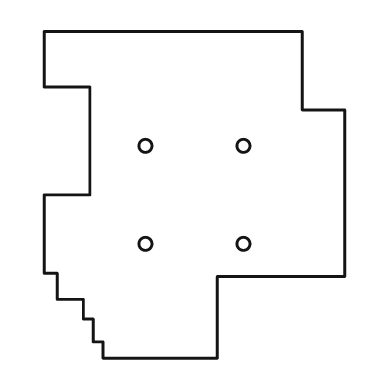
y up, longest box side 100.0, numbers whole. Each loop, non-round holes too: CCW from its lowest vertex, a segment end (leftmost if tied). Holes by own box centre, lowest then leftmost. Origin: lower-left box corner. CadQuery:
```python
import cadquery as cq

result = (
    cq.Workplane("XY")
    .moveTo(18.0, 0.0)
    .lineTo(53.0, 0.0)
    .lineTo(53.0, 25.0)
    .lineTo(92.0, 25.0)
    .lineTo(92.0, 76.0)
    .lineTo(79.0, 76.0)
    .lineTo(79.0, 100.0)
    .lineTo(0.0, 100.0)
    .lineTo(0.0, 83.0)
    .lineTo(14.0, 83.0)
    .lineTo(14.0, 50.0)
    .lineTo(0.0, 50.0)
    .lineTo(0.0, 26.0)
    .lineTo(4.0, 26.0)
    .lineTo(4.0, 18.0)
    .lineTo(12.0, 18.0)
    .lineTo(12.0, 12.0)
    .lineTo(15.0, 12.0)
    .lineTo(15.0, 5.0)
    .lineTo(18.0, 5.0)
    .close()
    .moveTo(31.0, 35.0)
    .circle(2.0)
    .moveTo(61.0, 35.0)
    .circle(2.0)
    .moveTo(31.0, 65.0)
    .circle(2.0)
    .moveTo(61.0, 65.0)
    .circle(2.0)
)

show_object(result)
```